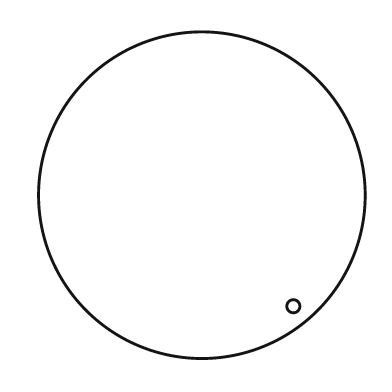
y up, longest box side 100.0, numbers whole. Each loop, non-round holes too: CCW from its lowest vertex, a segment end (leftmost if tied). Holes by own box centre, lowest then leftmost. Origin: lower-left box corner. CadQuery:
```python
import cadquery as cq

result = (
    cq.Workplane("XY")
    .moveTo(50.0, 50.0)
    .circle(50.0)
    .moveTo(78.0, 16.0)
    .circle(2.0)
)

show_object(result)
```